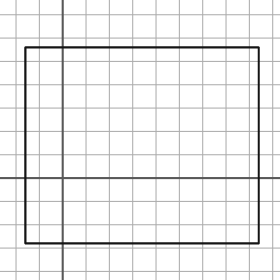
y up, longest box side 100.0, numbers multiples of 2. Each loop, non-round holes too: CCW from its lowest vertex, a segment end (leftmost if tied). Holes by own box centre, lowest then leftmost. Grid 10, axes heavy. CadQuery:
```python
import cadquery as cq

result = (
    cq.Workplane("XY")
    .moveTo(-16.0, -28.0)
    .lineTo(84.0, -28.0)
    .lineTo(84.0, 56.0)
    .lineTo(-16.0, 56.0)
    .close()
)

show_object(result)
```